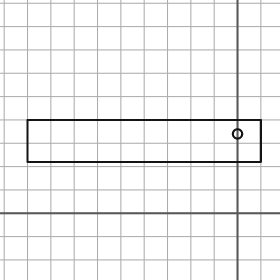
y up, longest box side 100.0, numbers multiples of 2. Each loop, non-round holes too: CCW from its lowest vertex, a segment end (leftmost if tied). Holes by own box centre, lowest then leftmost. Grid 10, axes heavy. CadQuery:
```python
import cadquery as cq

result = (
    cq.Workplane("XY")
    .moveTo(-90.0, 22.0)
    .lineTo(10.0, 22.0)
    .lineTo(10.0, 40.0)
    .lineTo(-90.0, 40.0)
    .close()
    .moveTo(0.0, 34.0)
    .circle(2.0)
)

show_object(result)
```